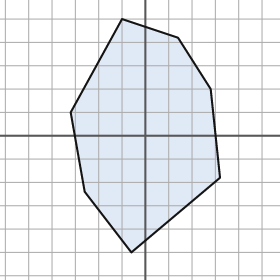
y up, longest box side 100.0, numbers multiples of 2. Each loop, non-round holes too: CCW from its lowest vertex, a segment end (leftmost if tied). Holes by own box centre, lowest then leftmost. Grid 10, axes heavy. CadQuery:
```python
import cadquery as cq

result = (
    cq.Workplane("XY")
    .moveTo(-6.0, -50.0)
    .lineTo(32.0, -18.0)
    .lineTo(28.0, 20.0)
    .lineTo(14.0, 42.0)
    .lineTo(-10.0, 50.0)
    .lineTo(-32.0, 10.0)
    .lineTo(-26.0, -24.0)
    .close()
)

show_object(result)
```